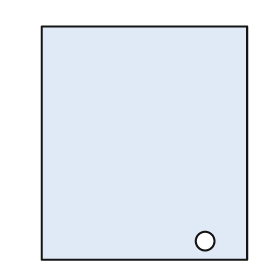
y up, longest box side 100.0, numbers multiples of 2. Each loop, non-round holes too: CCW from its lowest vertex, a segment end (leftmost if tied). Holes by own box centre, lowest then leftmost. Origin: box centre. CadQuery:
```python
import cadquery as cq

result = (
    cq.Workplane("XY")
    .moveTo(-44.0, -50.0)
    .lineTo(44.0, -50.0)
    .lineTo(44.0, 50.0)
    .lineTo(-44.0, 50.0)
    .close()
    .moveTo(26.0, -42.0)
    .circle(4.0)
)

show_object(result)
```